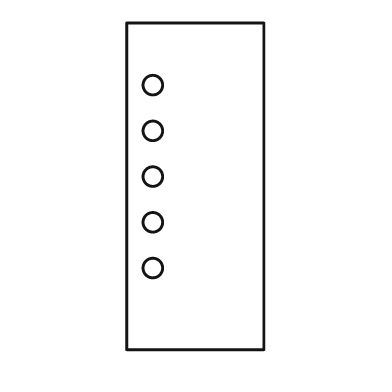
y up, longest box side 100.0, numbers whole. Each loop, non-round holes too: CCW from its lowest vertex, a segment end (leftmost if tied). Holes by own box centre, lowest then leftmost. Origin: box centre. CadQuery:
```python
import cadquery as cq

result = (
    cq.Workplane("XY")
    .moveTo(-21.0, -50.0)
    .lineTo(21.0, -50.0)
    .lineTo(21.0, 50.0)
    .lineTo(-21.0, 50.0)
    .close()
    .moveTo(-13.0, -25.0)
    .circle(3.0)
    .moveTo(-13.0, -11.0)
    .circle(3.0)
    .moveTo(-13.0, 3.0)
    .circle(3.0)
    .moveTo(-13.0, 17.0)
    .circle(3.0)
    .moveTo(-13.0, 31.0)
    .circle(3.0)
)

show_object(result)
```